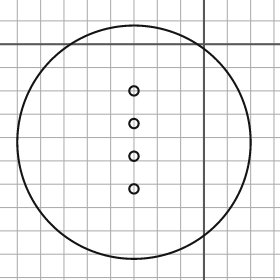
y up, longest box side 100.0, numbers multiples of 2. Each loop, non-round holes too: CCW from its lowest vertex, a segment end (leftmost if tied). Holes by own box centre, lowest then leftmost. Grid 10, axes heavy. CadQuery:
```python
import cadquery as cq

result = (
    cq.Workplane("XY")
    .moveTo(-30.0, -42.0)
    .circle(50.0)
    .moveTo(-30.0, -62.0)
    .circle(2.0)
    .moveTo(-30.0, -48.0)
    .circle(2.0)
    .moveTo(-30.0, -34.0)
    .circle(2.0)
    .moveTo(-30.0, -20.0)
    .circle(2.0)
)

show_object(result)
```